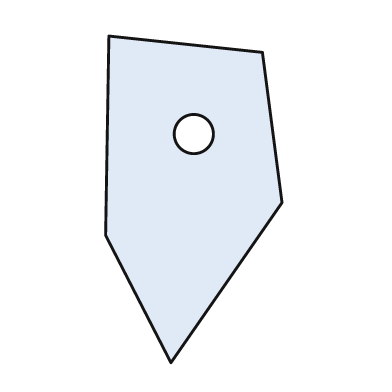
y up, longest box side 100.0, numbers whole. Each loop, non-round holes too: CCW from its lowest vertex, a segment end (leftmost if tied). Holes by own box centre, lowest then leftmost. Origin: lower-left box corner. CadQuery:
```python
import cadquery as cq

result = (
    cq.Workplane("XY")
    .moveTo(20.0, 0.0)
    .lineTo(54.0, 49.0)
    .lineTo(48.0, 95.0)
    .lineTo(1.0, 100.0)
    .lineTo(0.0, 39.0)
    .close()
    .moveTo(27.0, 70.0)
    .circle(6.0)
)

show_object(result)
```